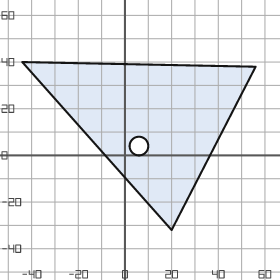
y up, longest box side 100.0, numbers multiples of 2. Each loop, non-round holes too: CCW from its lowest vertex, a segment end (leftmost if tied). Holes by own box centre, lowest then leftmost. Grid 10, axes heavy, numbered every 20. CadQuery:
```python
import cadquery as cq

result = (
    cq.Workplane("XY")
    .moveTo(20.0, -32.0)
    .lineTo(56.0, 38.0)
    .lineTo(-44.0, 40.0)
    .close()
    .moveTo(6.0, 4.0)
    .circle(4.0)
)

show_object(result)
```